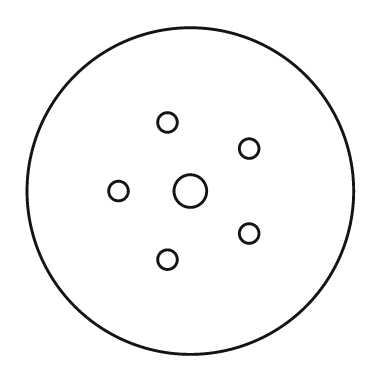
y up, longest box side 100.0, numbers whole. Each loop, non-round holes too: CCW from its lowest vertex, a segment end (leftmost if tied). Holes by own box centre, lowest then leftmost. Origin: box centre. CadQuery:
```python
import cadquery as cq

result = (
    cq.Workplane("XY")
    .moveTo(0.0, 0.0)
    .circle(50.0)
    .moveTo(-7.0, -21.0)
    .circle(3.0)
    .moveTo(18.0, -13.0)
    .circle(3.0)
    .moveTo(-22.0, 0.0)
    .circle(3.0)
    .moveTo(0.0, 0.0)
    .circle(5.0)
    .moveTo(18.0, 13.0)
    .circle(3.0)
    .moveTo(-7.0, 21.0)
    .circle(3.0)
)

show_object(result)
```